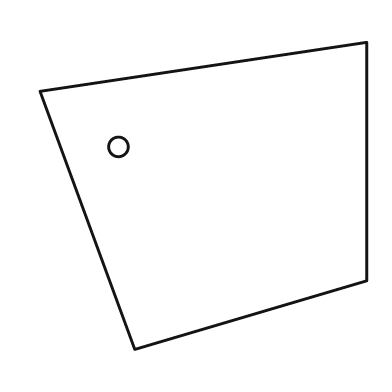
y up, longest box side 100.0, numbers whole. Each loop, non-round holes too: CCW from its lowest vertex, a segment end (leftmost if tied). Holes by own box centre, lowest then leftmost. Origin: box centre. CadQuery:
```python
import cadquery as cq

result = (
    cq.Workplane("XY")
    .moveTo(-21.0, -47.0)
    .lineTo(50.0, -26.0)
    .lineTo(50.0, 47.0)
    .lineTo(-50.0, 32.0)
    .close()
    .moveTo(-26.0, 15.0)
    .circle(3.0)
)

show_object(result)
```